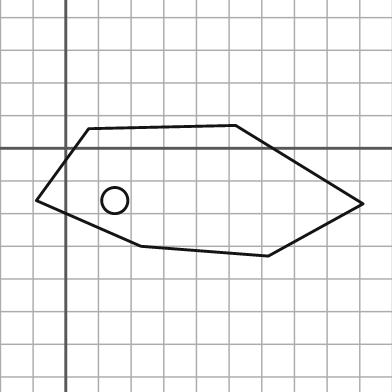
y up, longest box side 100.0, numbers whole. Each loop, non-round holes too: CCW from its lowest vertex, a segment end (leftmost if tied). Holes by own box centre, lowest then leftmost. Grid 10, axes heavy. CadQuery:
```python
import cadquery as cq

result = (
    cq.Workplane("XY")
    .moveTo(62.0, -33.0)
    .lineTo(91.0, -17.0)
    .lineTo(52.0, 7.0)
    .lineTo(7.0, 6.0)
    .lineTo(-9.0, -16.0)
    .lineTo(23.0, -30.0)
    .close()
    .moveTo(15.0, -16.0)
    .circle(4.0)
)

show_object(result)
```